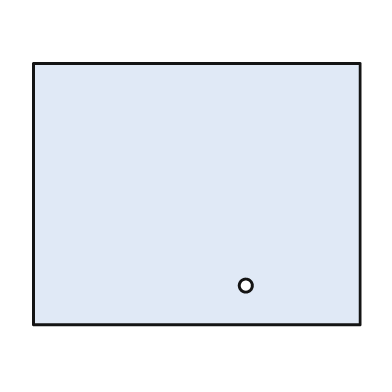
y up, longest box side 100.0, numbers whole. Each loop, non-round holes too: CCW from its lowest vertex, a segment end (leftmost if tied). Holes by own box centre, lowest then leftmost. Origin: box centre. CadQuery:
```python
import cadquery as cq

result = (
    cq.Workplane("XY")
    .moveTo(-50.0, -40.0)
    .lineTo(50.0, -40.0)
    .lineTo(50.0, 40.0)
    .lineTo(-50.0, 40.0)
    .close()
    .moveTo(15.0, -28.0)
    .circle(2.0)
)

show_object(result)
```